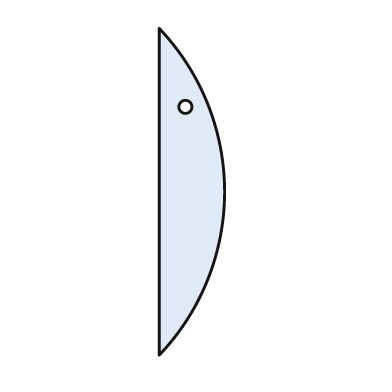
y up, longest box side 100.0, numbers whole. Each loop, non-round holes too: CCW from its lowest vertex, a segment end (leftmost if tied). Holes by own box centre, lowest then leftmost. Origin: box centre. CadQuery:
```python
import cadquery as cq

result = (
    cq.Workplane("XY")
    .moveTo(-10.0, -50.0)
    .threePointArc((10.0, 0.0), (-10.0, 50.0))
    .close()
    .moveTo(-2.0, 26.0)
    .circle(2.0)
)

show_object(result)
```